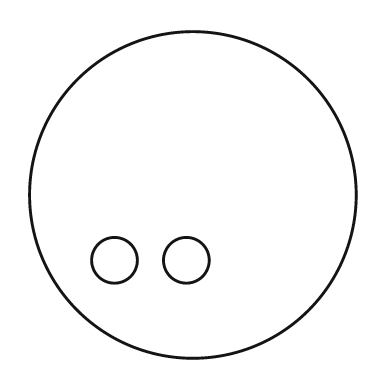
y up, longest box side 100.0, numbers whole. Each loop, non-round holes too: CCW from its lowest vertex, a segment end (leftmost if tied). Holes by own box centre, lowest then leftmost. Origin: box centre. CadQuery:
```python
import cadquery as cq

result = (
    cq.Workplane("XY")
    .moveTo(0.0, 0.0)
    .circle(50.0)
    .moveTo(-24.0, -20.0)
    .circle(7.0)
    .moveTo(-2.0, -20.0)
    .circle(7.0)
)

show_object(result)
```